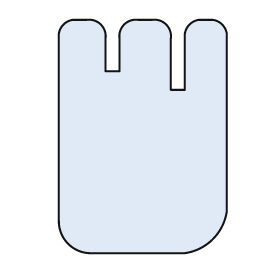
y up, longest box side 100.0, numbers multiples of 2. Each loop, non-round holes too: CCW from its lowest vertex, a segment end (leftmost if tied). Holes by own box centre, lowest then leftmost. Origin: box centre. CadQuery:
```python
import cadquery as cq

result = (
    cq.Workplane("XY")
    .moveTo(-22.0, -50.0)
    .lineTo(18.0, -50.0)
    .threePointArc((30.0, -44.0), (36.0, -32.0))
    .lineTo(36.0, 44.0)
    .threePointArc((34.0, 48.0), (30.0, 50.0))
    .lineTo(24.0, 50.0)
    .threePointArc((20.0, 48.0), (18.0, 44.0))
    .lineTo(18.0, 20.0)
    .lineTo(12.0, 20.0)
    .lineTo(12.0, 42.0)
    .threePointArc((10.0, 48.0), (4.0, 50.0))
    .lineTo(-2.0, 50.0)
    .threePointArc((-8.0, 48.0), (-10.0, 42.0))
    .lineTo(-10.0, 28.0)
    .lineTo(-16.0, 28.0)
    .lineTo(-16.0, 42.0)
    .threePointArc((-18.0, 48.0), (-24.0, 50.0))
    .lineTo(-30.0, 50.0)
    .threePointArc((-34.0, 48.0), (-36.0, 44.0))
    .lineTo(-36.0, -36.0)
    .threePointArc((-32.0, -46.0), (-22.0, -50.0))
    .close()
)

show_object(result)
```